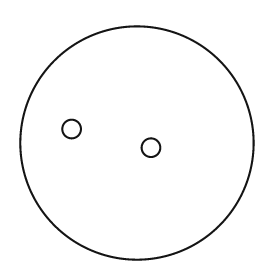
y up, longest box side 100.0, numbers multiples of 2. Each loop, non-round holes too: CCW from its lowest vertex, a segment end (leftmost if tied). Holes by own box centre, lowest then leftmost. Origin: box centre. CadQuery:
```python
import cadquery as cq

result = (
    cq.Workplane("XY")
    .moveTo(0.0, 0.0)
    .circle(50.0)
    .moveTo(6.0, -2.0)
    .circle(4.0)
    .moveTo(-28.0, 6.0)
    .circle(4.0)
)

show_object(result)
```